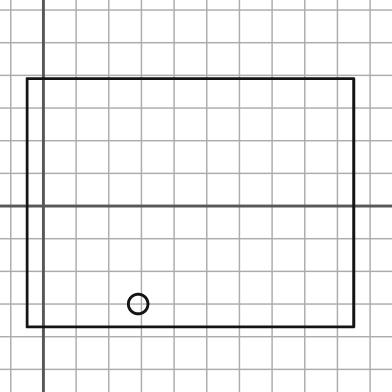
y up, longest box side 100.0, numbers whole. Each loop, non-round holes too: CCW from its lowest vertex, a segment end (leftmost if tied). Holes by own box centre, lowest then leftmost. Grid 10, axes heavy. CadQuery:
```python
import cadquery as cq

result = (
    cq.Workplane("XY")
    .moveTo(-5.0, -37.0)
    .lineTo(95.0, -37.0)
    .lineTo(95.0, 39.0)
    .lineTo(-5.0, 39.0)
    .close()
    .moveTo(29.0, -30.0)
    .circle(3.0)
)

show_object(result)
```